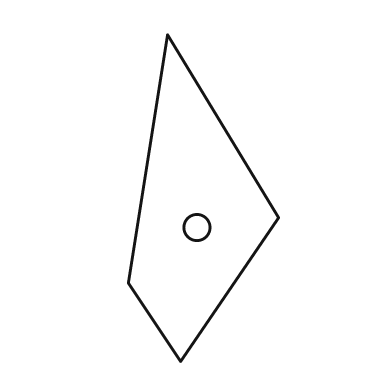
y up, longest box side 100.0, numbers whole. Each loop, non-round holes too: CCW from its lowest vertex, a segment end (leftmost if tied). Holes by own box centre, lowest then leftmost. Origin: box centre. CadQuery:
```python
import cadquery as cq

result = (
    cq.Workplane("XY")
    .moveTo(-7.0, -50.0)
    .lineTo(23.0, -6.0)
    .lineTo(-11.0, 50.0)
    .lineTo(-23.0, -26.0)
    .close()
    .moveTo(-2.0, -9.0)
    .circle(4.0)
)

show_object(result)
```